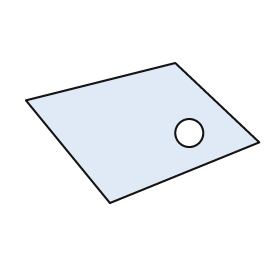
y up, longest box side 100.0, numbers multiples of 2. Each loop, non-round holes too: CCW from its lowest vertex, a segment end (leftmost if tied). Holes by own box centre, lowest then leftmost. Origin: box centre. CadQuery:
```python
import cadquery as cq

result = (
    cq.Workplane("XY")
    .moveTo(-14.0, -30.0)
    .lineTo(50.0, -4.0)
    .lineTo(14.0, 30.0)
    .lineTo(-50.0, 14.0)
    .close()
    .moveTo(20.0, 0.0)
    .circle(6.0)
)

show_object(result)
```